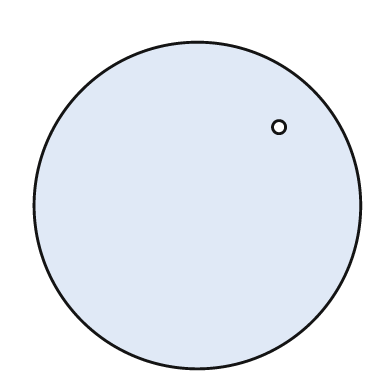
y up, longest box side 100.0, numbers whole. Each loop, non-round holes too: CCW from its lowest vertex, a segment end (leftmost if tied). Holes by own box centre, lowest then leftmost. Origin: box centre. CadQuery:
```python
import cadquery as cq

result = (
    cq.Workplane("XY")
    .moveTo(0.0, 0.0)
    .circle(50.0)
    .moveTo(25.0, 24.0)
    .circle(2.0)
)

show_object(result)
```